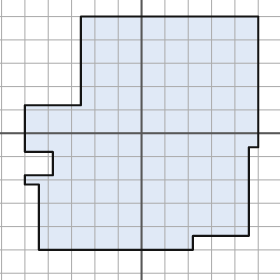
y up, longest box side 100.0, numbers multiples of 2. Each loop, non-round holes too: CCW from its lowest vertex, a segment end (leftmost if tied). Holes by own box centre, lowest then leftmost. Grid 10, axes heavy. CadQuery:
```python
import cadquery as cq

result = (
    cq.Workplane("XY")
    .moveTo(-44.0, -50.0)
    .lineTo(22.0, -50.0)
    .lineTo(22.0, -44.0)
    .lineTo(46.0, -44.0)
    .lineTo(46.0, -6.0)
    .lineTo(50.0, -6.0)
    .lineTo(50.0, 50.0)
    .lineTo(-26.0, 50.0)
    .lineTo(-26.0, 12.0)
    .lineTo(-50.0, 12.0)
    .lineTo(-50.0, -8.0)
    .lineTo(-38.0, -8.0)
    .lineTo(-38.0, -18.0)
    .lineTo(-50.0, -18.0)
    .lineTo(-50.0, -22.0)
    .lineTo(-44.0, -22.0)
    .close()
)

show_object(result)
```